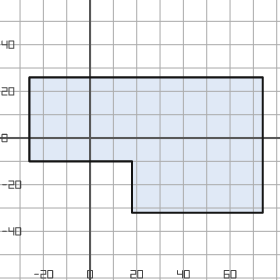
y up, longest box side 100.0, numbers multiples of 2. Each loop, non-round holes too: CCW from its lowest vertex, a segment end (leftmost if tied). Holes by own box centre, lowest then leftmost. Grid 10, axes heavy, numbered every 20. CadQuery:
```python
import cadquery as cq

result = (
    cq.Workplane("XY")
    .moveTo(18.0, -32.0)
    .lineTo(74.0, -32.0)
    .lineTo(74.0, 26.0)
    .lineTo(-26.0, 26.0)
    .lineTo(-26.0, -10.0)
    .lineTo(18.0, -10.0)
    .close()
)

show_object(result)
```